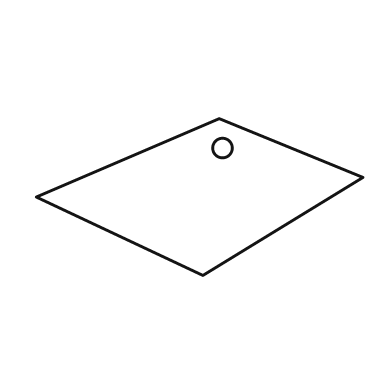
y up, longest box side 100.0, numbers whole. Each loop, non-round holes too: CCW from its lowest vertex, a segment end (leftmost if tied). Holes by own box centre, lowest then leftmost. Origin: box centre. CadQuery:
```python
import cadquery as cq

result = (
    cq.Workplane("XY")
    .moveTo(1.0, -24.0)
    .lineTo(50.0, 6.0)
    .lineTo(6.0, 24.0)
    .lineTo(-50.0, 0.0)
    .close()
    .moveTo(7.0, 15.0)
    .circle(3.0)
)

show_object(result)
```